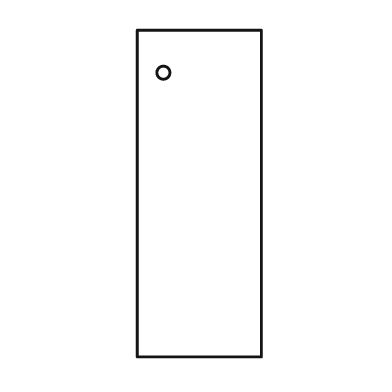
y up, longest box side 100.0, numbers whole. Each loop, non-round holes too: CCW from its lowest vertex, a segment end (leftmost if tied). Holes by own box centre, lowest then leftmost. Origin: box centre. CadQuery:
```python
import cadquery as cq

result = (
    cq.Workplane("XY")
    .moveTo(-19.0, -50.0)
    .lineTo(19.0, -50.0)
    .lineTo(19.0, 50.0)
    .lineTo(-19.0, 50.0)
    .close()
    .moveTo(-11.0, 37.0)
    .circle(2.0)
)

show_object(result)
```